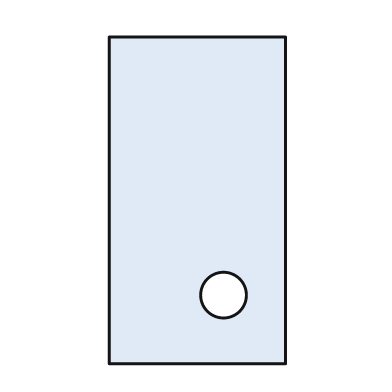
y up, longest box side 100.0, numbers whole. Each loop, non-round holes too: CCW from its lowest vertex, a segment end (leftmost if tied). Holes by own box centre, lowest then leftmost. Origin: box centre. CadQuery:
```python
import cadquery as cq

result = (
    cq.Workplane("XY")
    .moveTo(-27.0, -50.0)
    .lineTo(27.0, -50.0)
    .lineTo(27.0, 50.0)
    .lineTo(-27.0, 50.0)
    .close()
    .moveTo(8.0, -29.0)
    .circle(7.0)
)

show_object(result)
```